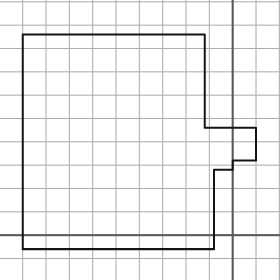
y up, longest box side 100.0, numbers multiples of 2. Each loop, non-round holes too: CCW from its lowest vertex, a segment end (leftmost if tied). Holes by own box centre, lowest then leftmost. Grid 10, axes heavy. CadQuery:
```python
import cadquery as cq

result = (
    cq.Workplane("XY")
    .moveTo(-90.0, -6.0)
    .lineTo(-8.0, -6.0)
    .lineTo(-8.0, 28.0)
    .lineTo(0.0, 28.0)
    .lineTo(0.0, 32.0)
    .lineTo(10.0, 32.0)
    .lineTo(10.0, 46.0)
    .lineTo(-12.0, 46.0)
    .lineTo(-12.0, 86.0)
    .lineTo(-90.0, 86.0)
    .close()
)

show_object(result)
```